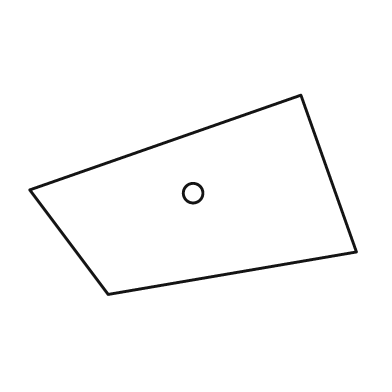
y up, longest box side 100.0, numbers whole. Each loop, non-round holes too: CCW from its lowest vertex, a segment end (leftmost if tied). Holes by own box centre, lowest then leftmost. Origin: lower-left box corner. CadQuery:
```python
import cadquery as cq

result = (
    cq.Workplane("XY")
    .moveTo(24.0, 0.0)
    .lineTo(100.0, 13.0)
    .lineTo(83.0, 61.0)
    .lineTo(0.0, 32.0)
    .close()
    .moveTo(50.0, 31.0)
    .circle(3.0)
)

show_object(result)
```